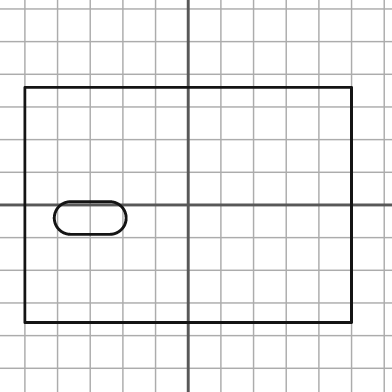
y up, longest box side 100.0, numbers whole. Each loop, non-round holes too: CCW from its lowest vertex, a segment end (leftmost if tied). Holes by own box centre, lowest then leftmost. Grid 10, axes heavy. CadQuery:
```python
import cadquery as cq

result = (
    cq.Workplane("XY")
    .moveTo(-50.0, -36.0)
    .lineTo(50.0, -36.0)
    .lineTo(50.0, 36.0)
    .lineTo(-50.0, 36.0)
    .close()
    .moveTo(-36.0, -9.0)
    .lineTo(-24.0, -9.0)
    .threePointArc((-19.0, -4.0), (-24.0, 1.0))
    .lineTo(-36.0, 1.0)
    .threePointArc((-41.0, -4.0), (-36.0, -9.0))
    .close()
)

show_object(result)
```